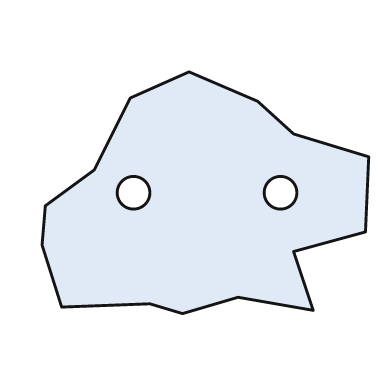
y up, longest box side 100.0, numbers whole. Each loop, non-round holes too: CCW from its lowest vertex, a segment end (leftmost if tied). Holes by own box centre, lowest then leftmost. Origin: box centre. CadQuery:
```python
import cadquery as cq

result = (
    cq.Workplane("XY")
    .moveTo(-7.0, -37.0)
    .lineTo(10.0, -32.0)
    .lineTo(33.0, -36.0)
    .lineTo(27.0, -18.0)
    .lineTo(49.0, -12.0)
    .lineTo(50.0, 11.0)
    .lineTo(27.0, 18.0)
    .lineTo(16.0, 28.0)
    .lineTo(-5.0, 37.0)
    .lineTo(-23.0, 29.0)
    .lineTo(-34.0, 7.0)
    .lineTo(-49.0, -4.0)
    .lineTo(-50.0, -16.0)
    .lineTo(-44.0, -35.0)
    .lineTo(-17.0, -34.0)
    .close()
    .moveTo(-22.0, 0.0)
    .circle(5.0)
    .moveTo(23.0, 0.0)
    .circle(5.0)
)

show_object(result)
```